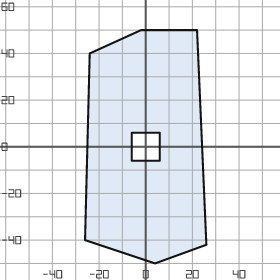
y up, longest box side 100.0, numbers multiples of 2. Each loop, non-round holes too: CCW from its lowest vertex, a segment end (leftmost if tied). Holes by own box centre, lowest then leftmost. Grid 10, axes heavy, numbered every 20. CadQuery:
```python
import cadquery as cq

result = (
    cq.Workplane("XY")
    .moveTo(4.0, -50.0)
    .lineTo(26.0, -42.0)
    .lineTo(22.0, 50.0)
    .lineTo(-2.0, 50.0)
    .lineTo(-24.0, 40.0)
    .lineTo(-26.0, -40.0)
    .close()
    .moveTo(-6.0, -6.0)
    .lineTo(6.0, -6.0)
    .lineTo(6.0, 6.0)
    .lineTo(-6.0, 6.0)
    .close()
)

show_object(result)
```